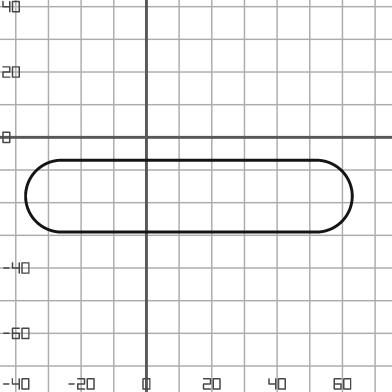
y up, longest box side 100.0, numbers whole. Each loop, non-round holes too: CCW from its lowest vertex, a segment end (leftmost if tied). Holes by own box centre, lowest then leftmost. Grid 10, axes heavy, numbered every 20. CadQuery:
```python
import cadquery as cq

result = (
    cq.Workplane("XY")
    .moveTo(-26.0, -29.0)
    .lineTo(52.0, -29.0)
    .threePointArc((63.0, -18.0), (52.0, -7.0))
    .lineTo(-26.0, -7.0)
    .threePointArc((-37.0, -18.0), (-26.0, -29.0))
    .close()
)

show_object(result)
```